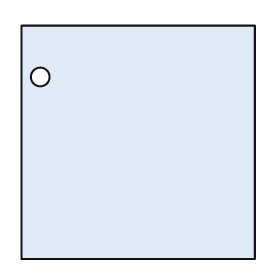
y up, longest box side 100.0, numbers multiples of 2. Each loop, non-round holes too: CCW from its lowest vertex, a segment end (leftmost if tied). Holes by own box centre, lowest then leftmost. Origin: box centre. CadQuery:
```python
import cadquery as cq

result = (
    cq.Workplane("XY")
    .moveTo(-50.0, -50.0)
    .lineTo(50.0, -50.0)
    .lineTo(50.0, 50.0)
    .lineTo(-50.0, 50.0)
    .close()
    .moveTo(-42.0, 28.0)
    .circle(4.0)
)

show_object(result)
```